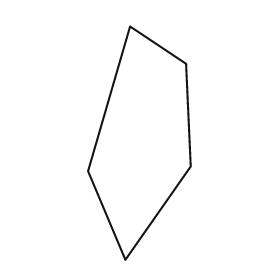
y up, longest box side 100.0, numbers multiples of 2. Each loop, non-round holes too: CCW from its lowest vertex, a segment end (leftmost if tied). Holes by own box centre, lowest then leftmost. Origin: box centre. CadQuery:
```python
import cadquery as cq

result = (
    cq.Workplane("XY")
    .moveTo(-6.0, -50.0)
    .lineTo(22.0, -10.0)
    .lineTo(20.0, 34.0)
    .lineTo(-4.0, 50.0)
    .lineTo(-22.0, -12.0)
    .close()
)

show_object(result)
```